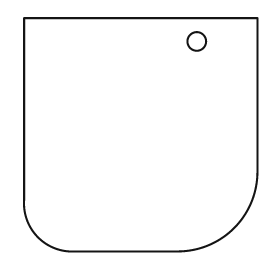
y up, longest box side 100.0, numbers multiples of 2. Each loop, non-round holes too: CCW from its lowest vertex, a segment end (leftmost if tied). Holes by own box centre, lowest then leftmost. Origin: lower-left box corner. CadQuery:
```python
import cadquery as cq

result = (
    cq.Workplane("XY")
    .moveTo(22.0, 0.0)
    .lineTo(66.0, 0.0)
    .threePointArc((90.0, 10.0), (100.0, 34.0))
    .lineTo(100.0, 100.0)
    .lineTo(0.0, 100.0)
    .lineTo(0.0, 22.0)
    .threePointArc((6.0, 6.0), (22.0, 0.0))
    .close()
    .moveTo(74.0, 90.0)
    .circle(4.0)
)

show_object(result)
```